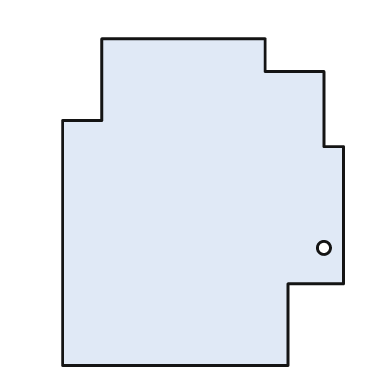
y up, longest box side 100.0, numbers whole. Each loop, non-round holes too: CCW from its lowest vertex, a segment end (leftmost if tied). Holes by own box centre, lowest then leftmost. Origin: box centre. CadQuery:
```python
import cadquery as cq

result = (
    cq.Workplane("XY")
    .moveTo(-43.0, -50.0)
    .lineTo(26.0, -50.0)
    .lineTo(26.0, -25.0)
    .lineTo(43.0, -25.0)
    .lineTo(43.0, 17.0)
    .lineTo(37.0, 17.0)
    .lineTo(37.0, 40.0)
    .lineTo(19.0, 40.0)
    .lineTo(19.0, 50.0)
    .lineTo(-31.0, 50.0)
    .lineTo(-31.0, 25.0)
    .lineTo(-43.0, 25.0)
    .close()
    .moveTo(37.0, -14.0)
    .circle(2.0)
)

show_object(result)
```